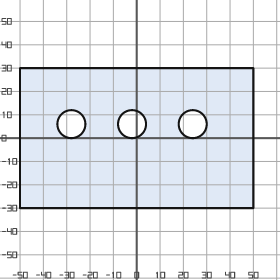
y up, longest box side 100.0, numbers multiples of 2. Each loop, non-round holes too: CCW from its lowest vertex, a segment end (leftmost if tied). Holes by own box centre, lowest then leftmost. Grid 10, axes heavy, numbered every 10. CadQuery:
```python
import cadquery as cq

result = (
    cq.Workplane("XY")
    .moveTo(-50.0, -30.0)
    .lineTo(50.0, -30.0)
    .lineTo(50.0, 30.0)
    .lineTo(-50.0, 30.0)
    .close()
    .moveTo(-28.0, 6.0)
    .circle(6.0)
    .moveTo(-2.0, 6.0)
    .circle(6.0)
    .moveTo(24.0, 6.0)
    .circle(6.0)
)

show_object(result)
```